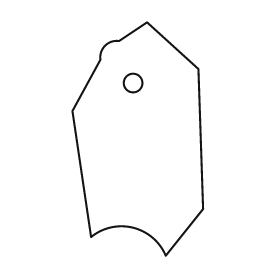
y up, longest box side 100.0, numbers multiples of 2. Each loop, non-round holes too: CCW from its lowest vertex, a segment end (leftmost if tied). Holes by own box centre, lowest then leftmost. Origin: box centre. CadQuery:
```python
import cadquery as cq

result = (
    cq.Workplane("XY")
    .moveTo(12.0, -50.0)
    .lineTo(28.0, -30.0)
    .lineTo(26.0, 30.0)
    .lineTo(4.0, 50.0)
    .lineTo(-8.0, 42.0)
    .threePointArc((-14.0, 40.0), (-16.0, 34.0))
    .lineTo(-28.0, 12.0)
    .lineTo(-20.0, -42.0)
    .threePointArc((-2.0, -38.0), (12.0, -50.0))
    .close()
    .moveTo(-2.0, 24.0)
    .circle(4.0)
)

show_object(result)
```